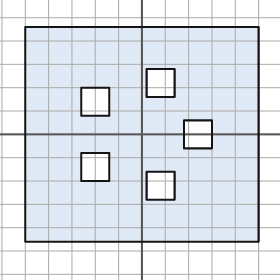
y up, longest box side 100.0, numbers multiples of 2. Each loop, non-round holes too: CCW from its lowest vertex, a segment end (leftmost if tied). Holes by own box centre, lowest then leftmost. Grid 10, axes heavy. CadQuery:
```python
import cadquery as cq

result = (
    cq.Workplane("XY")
    .moveTo(-50.0, -46.0)
    .lineTo(50.0, -46.0)
    .lineTo(50.0, 46.0)
    .lineTo(-50.0, 46.0)
    .close()
    .moveTo(2.0, -28.0)
    .lineTo(14.0, -28.0)
    .lineTo(14.0, -16.0)
    .lineTo(2.0, -16.0)
    .close()
    .moveTo(-26.0, -20.0)
    .lineTo(-14.0, -20.0)
    .lineTo(-14.0, -8.0)
    .lineTo(-26.0, -8.0)
    .close()
    .moveTo(18.0, -6.0)
    .lineTo(30.0, -6.0)
    .lineTo(30.0, 6.0)
    .lineTo(18.0, 6.0)
    .close()
    .moveTo(-26.0, 8.0)
    .lineTo(-14.0, 8.0)
    .lineTo(-14.0, 20.0)
    .lineTo(-26.0, 20.0)
    .close()
    .moveTo(2.0, 16.0)
    .lineTo(14.0, 16.0)
    .lineTo(14.0, 28.0)
    .lineTo(2.0, 28.0)
    .close()
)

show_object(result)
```